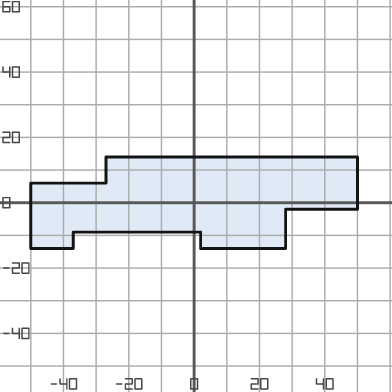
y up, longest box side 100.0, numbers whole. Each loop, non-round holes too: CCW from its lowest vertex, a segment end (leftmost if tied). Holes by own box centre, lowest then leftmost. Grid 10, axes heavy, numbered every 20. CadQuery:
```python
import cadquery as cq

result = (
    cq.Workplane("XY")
    .moveTo(-50.0, -14.0)
    .lineTo(-37.0, -14.0)
    .lineTo(-37.0, -9.0)
    .lineTo(2.0, -9.0)
    .lineTo(2.0, -14.0)
    .lineTo(28.0, -14.0)
    .lineTo(28.0, -2.0)
    .lineTo(50.0, -2.0)
    .lineTo(50.0, 14.0)
    .lineTo(-27.0, 14.0)
    .lineTo(-27.0, 6.0)
    .lineTo(-50.0, 6.0)
    .close()
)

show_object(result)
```